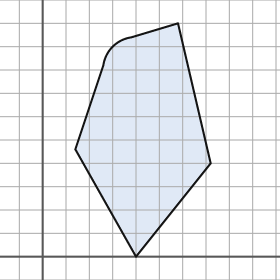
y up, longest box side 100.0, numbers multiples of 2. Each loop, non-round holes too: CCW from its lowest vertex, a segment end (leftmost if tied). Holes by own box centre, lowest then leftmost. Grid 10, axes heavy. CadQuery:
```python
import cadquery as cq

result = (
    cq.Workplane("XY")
    .moveTo(40.0, 0.0)
    .lineTo(72.0, 40.0)
    .lineTo(58.0, 100.0)
    .lineTo(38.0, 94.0)
    .threePointArc((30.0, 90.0), (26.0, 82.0))
    .lineTo(14.0, 46.0)
    .close()
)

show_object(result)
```